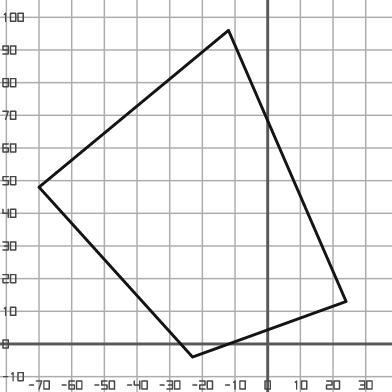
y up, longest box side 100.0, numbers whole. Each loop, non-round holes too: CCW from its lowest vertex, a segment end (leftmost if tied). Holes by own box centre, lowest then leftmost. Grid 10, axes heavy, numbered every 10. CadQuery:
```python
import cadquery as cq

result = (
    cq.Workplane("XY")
    .moveTo(-23.0, -4.0)
    .lineTo(24.0, 13.0)
    .lineTo(-12.0, 96.0)
    .lineTo(-70.0, 48.0)
    .close()
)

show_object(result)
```